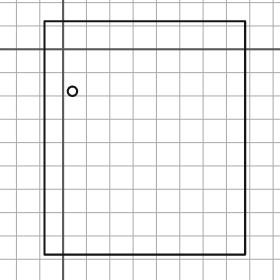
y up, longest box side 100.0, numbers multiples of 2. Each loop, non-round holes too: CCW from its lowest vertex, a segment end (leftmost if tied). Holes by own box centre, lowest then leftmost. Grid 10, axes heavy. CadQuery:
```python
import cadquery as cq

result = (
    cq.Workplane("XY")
    .moveTo(-8.0, -88.0)
    .lineTo(78.0, -88.0)
    .lineTo(78.0, 12.0)
    .lineTo(-8.0, 12.0)
    .close()
    .moveTo(4.0, -18.0)
    .circle(2.0)
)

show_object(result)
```